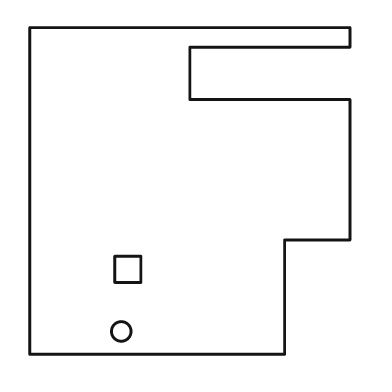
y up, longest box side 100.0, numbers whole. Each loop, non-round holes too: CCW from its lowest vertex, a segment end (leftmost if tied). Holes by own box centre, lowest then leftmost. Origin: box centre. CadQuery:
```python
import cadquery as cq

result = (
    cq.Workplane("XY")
    .moveTo(-49.0, -50.0)
    .lineTo(29.0, -50.0)
    .lineTo(29.0, -15.0)
    .lineTo(49.0, -15.0)
    .lineTo(49.0, 28.0)
    .lineTo(0.0, 28.0)
    .lineTo(0.0, 44.0)
    .lineTo(49.0, 44.0)
    .lineTo(49.0, 50.0)
    .lineTo(-49.0, 50.0)
    .close()
    .moveTo(-21.0, -43.0)
    .circle(3.0)
    .moveTo(-23.0, -28.0)
    .lineTo(-15.0, -28.0)
    .lineTo(-15.0, -20.0)
    .lineTo(-23.0, -20.0)
    .close()
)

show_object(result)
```